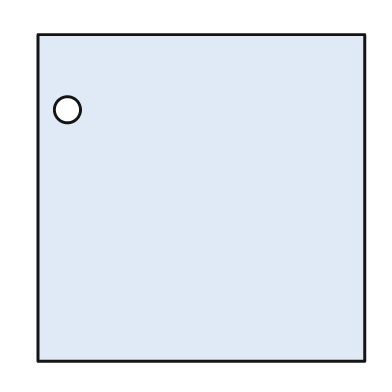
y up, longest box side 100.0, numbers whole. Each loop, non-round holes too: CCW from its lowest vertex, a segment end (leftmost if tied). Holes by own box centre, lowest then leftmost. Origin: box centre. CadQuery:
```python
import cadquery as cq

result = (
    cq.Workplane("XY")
    .moveTo(-50.0, -50.0)
    .lineTo(50.0, -50.0)
    .lineTo(50.0, 50.0)
    .lineTo(-50.0, 50.0)
    .close()
    .moveTo(-41.0, 27.0)
    .circle(4.0)
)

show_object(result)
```